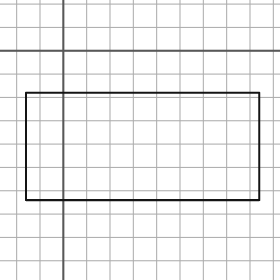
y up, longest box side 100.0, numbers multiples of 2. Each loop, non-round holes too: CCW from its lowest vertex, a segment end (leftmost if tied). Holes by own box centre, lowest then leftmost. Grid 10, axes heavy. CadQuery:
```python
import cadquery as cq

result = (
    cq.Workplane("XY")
    .moveTo(-16.0, -64.0)
    .lineTo(84.0, -64.0)
    .lineTo(84.0, -18.0)
    .lineTo(-16.0, -18.0)
    .close()
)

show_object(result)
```